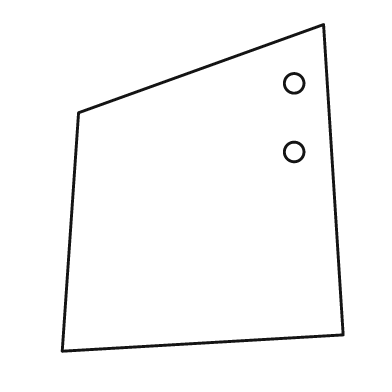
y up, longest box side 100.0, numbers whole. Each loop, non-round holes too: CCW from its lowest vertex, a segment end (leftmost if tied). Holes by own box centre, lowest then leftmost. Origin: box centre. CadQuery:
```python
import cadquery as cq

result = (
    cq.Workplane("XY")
    .moveTo(-43.0, -50.0)
    .lineTo(43.0, -45.0)
    .lineTo(37.0, 50.0)
    .lineTo(-38.0, 23.0)
    .close()
    .moveTo(28.0, 11.0)
    .circle(3.0)
    .moveTo(28.0, 32.0)
    .circle(3.0)
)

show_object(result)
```